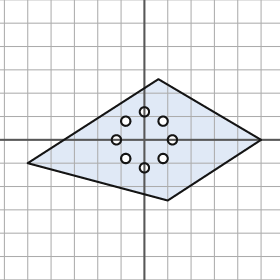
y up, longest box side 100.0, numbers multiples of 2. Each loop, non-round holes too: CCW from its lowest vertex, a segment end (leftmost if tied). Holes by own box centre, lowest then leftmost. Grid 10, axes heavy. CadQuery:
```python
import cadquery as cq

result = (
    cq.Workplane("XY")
    .moveTo(10.0, -26.0)
    .lineTo(50.0, 0.0)
    .lineTo(6.0, 26.0)
    .lineTo(-50.0, -10.0)
    .close()
    .moveTo(0.0, -12.0)
    .circle(2.0)
    .moveTo(-8.0, -8.0)
    .circle(2.0)
    .moveTo(8.0, -8.0)
    .circle(2.0)
    .moveTo(-12.0, 0.0)
    .circle(2.0)
    .moveTo(12.0, 0.0)
    .circle(2.0)
    .moveTo(-8.0, 8.0)
    .circle(2.0)
    .moveTo(8.0, 8.0)
    .circle(2.0)
    .moveTo(0.0, 12.0)
    .circle(2.0)
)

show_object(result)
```